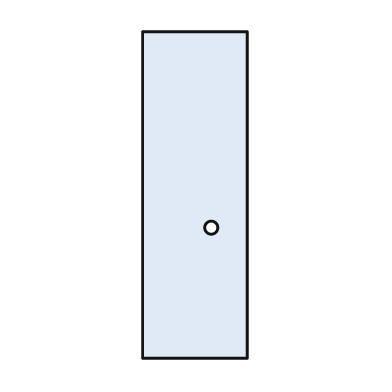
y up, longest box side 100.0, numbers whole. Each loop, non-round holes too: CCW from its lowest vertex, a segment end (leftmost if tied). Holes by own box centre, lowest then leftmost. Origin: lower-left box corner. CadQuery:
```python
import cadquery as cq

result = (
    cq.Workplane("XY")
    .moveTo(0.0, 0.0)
    .lineTo(32.0, 0.0)
    .lineTo(32.0, 100.0)
    .lineTo(0.0, 100.0)
    .close()
    .moveTo(21.0, 40.0)
    .circle(2.0)
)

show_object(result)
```